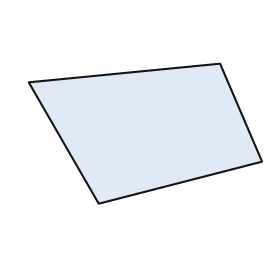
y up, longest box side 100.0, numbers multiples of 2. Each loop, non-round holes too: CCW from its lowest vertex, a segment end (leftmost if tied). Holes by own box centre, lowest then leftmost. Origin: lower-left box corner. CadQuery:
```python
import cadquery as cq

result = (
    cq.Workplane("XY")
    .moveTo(30.0, 0.0)
    .lineTo(100.0, 18.0)
    .lineTo(82.0, 60.0)
    .lineTo(0.0, 52.0)
    .close()
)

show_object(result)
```